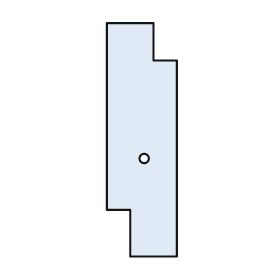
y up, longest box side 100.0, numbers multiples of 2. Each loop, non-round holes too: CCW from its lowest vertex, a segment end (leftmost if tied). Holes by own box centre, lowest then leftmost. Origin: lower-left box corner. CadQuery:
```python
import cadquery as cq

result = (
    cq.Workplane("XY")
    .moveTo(10.0, 0.0)
    .lineTo(30.0, 0.0)
    .lineTo(30.0, 84.0)
    .lineTo(20.0, 84.0)
    .lineTo(20.0, 100.0)
    .lineTo(0.0, 100.0)
    .lineTo(0.0, 20.0)
    .lineTo(10.0, 20.0)
    .close()
    .moveTo(16.0, 42.0)
    .circle(2.0)
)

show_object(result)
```